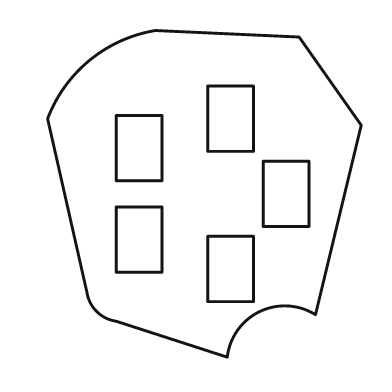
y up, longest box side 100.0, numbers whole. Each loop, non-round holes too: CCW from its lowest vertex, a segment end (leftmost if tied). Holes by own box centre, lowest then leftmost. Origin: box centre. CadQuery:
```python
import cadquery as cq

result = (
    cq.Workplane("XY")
    .moveTo(7.0, -50.0)
    .threePointArc((17.0, -36.0), (34.0, -37.0))
    .lineTo(48.0, 21.0)
    .lineTo(29.0, 48.0)
    .lineTo(-15.0, 50.0)
    .threePointArc((-35.0, 41.0), (-48.0, 23.0))
    .lineTo(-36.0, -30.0)
    .threePointArc((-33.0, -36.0), (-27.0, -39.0))
    .close()
    .moveTo(1.0, -33.0)
    .lineTo(15.0, -33.0)
    .lineTo(15.0, -13.0)
    .lineTo(1.0, -13.0)
    .close()
    .moveTo(-27.0, -24.0)
    .lineTo(-13.0, -24.0)
    .lineTo(-13.0, -4.0)
    .lineTo(-27.0, -4.0)
    .close()
    .moveTo(18.0, -10.0)
    .lineTo(32.0, -10.0)
    .lineTo(32.0, 10.0)
    .lineTo(18.0, 10.0)
    .close()
    .moveTo(-27.0, 4.0)
    .lineTo(-13.0, 4.0)
    .lineTo(-13.0, 24.0)
    .lineTo(-27.0, 24.0)
    .close()
    .moveTo(1.0, 13.0)
    .lineTo(15.0, 13.0)
    .lineTo(15.0, 33.0)
    .lineTo(1.0, 33.0)
    .close()
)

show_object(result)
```